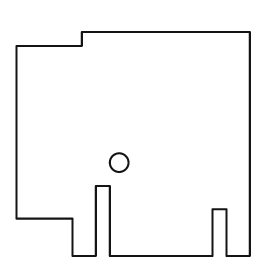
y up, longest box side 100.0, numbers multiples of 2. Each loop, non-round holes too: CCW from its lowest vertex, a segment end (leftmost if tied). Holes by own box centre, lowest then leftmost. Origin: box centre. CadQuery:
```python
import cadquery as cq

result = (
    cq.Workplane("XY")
    .moveTo(-26.0, -48.0)
    .lineTo(-16.0, -48.0)
    .lineTo(-16.0, -18.0)
    .lineTo(-10.0, -18.0)
    .lineTo(-10.0, -48.0)
    .lineTo(34.0, -48.0)
    .lineTo(34.0, -28.0)
    .lineTo(40.0, -28.0)
    .lineTo(40.0, -48.0)
    .lineTo(50.0, -48.0)
    .lineTo(50.0, 48.0)
    .lineTo(-22.0, 48.0)
    .lineTo(-22.0, 42.0)
    .lineTo(-50.0, 42.0)
    .lineTo(-50.0, -32.0)
    .lineTo(-26.0, -32.0)
    .close()
    .moveTo(-6.0, -8.0)
    .circle(4.0)
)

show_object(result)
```